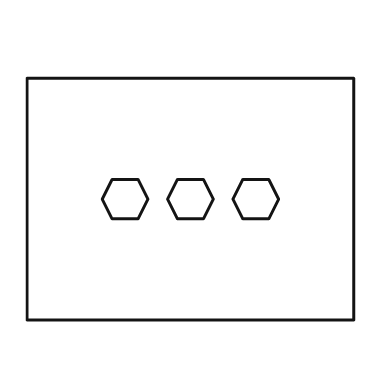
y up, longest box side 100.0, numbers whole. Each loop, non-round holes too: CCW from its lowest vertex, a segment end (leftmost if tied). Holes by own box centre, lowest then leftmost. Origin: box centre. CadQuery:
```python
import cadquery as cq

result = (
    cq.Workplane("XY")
    .moveTo(-50.0, -37.0)
    .lineTo(50.0, -37.0)
    .lineTo(50.0, 37.0)
    .lineTo(-50.0, 37.0)
    .close()
    .moveTo(-24.0, -6.0)
    .lineTo(-16.0, -6.0)
    .lineTo(-13.0, 0.0)
    .lineTo(-16.0, 6.0)
    .lineTo(-24.0, 6.0)
    .lineTo(-27.0, 0.0)
    .close()
    .moveTo(-4.0, -6.0)
    .lineTo(4.0, -6.0)
    .lineTo(7.0, 0.0)
    .lineTo(4.0, 6.0)
    .lineTo(-4.0, 6.0)
    .lineTo(-7.0, 0.0)
    .close()
    .moveTo(16.0, -6.0)
    .lineTo(24.0, -6.0)
    .lineTo(27.0, 0.0)
    .lineTo(24.0, 6.0)
    .lineTo(16.0, 6.0)
    .lineTo(13.0, 0.0)
    .close()
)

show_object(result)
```